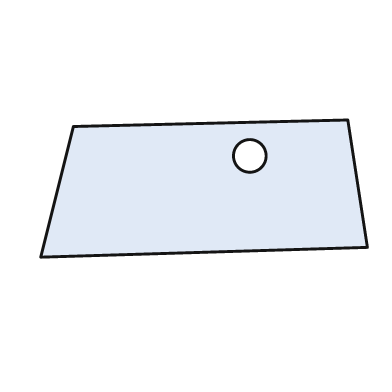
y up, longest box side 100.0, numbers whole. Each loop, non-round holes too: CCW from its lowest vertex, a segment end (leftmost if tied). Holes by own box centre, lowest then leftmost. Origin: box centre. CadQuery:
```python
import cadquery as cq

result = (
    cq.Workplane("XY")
    .moveTo(-50.0, -21.0)
    .lineTo(50.0, -18.0)
    .lineTo(44.0, 21.0)
    .lineTo(-40.0, 19.0)
    .close()
    .moveTo(14.0, 10.0)
    .circle(5.0)
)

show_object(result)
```